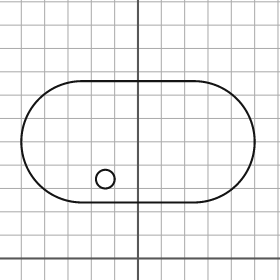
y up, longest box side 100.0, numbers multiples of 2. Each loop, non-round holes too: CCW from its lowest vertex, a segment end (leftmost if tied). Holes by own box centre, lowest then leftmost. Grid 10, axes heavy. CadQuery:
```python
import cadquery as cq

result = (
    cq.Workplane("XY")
    .moveTo(-24.0, 24.0)
    .lineTo(24.0, 24.0)
    .threePointArc((50.0, 50.0), (24.0, 76.0))
    .lineTo(-24.0, 76.0)
    .threePointArc((-50.0, 50.0), (-24.0, 24.0))
    .close()
    .moveTo(-14.0, 34.0)
    .circle(4.0)
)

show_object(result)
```